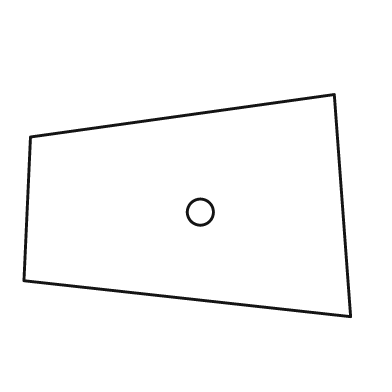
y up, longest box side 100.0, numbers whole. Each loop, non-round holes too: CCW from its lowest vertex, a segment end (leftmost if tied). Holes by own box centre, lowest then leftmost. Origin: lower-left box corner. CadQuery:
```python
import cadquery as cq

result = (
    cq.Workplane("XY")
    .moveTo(100.0, 0.0)
    .lineTo(95.0, 68.0)
    .lineTo(2.0, 55.0)
    .lineTo(0.0, 11.0)
    .close()
    .moveTo(54.0, 32.0)
    .circle(4.0)
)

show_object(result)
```